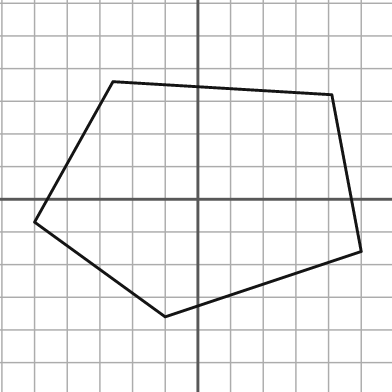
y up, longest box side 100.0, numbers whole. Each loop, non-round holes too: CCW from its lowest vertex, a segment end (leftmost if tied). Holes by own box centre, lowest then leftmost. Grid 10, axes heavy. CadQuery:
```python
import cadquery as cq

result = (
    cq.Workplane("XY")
    .moveTo(-10.0, -36.0)
    .lineTo(50.0, -16.0)
    .lineTo(41.0, 32.0)
    .lineTo(-26.0, 36.0)
    .lineTo(-50.0, -7.0)
    .close()
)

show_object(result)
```